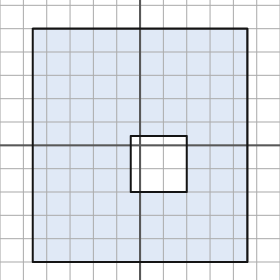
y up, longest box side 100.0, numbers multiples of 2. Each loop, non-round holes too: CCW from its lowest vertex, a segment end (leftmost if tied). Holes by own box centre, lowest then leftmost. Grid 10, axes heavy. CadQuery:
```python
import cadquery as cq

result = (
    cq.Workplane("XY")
    .moveTo(-46.0, -50.0)
    .lineTo(46.0, -50.0)
    .lineTo(46.0, 50.0)
    .lineTo(-46.0, 50.0)
    .close()
    .moveTo(-4.0, -20.0)
    .lineTo(20.0, -20.0)
    .lineTo(20.0, 4.0)
    .lineTo(-4.0, 4.0)
    .close()
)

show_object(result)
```